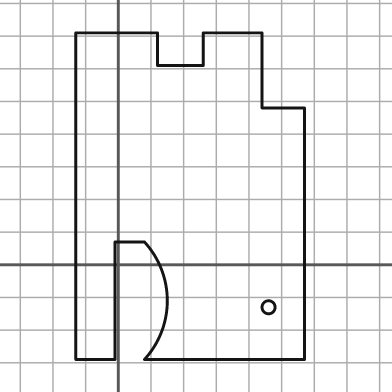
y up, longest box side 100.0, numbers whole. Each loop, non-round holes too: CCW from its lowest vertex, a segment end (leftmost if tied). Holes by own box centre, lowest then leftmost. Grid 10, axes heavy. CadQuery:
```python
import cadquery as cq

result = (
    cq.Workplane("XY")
    .moveTo(-13.0, -29.0)
    .lineTo(-1.0, -29.0)
    .lineTo(-1.0, 7.0)
    .lineTo(8.0, 7.0)
    .threePointArc((15.0, -11.0), (8.0, -29.0))
    .lineTo(57.0, -29.0)
    .lineTo(57.0, 48.0)
    .lineTo(44.0, 48.0)
    .lineTo(44.0, 71.0)
    .lineTo(26.0, 71.0)
    .lineTo(26.0, 61.0)
    .lineTo(12.0, 61.0)
    .lineTo(12.0, 71.0)
    .lineTo(-13.0, 71.0)
    .close()
    .moveTo(46.0, -13.0)
    .circle(2.0)
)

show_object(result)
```